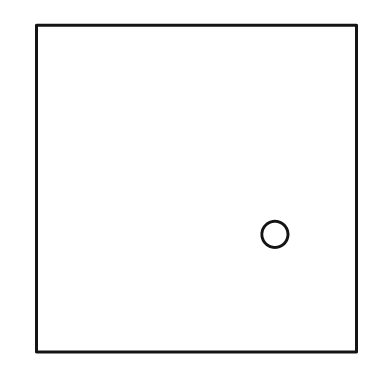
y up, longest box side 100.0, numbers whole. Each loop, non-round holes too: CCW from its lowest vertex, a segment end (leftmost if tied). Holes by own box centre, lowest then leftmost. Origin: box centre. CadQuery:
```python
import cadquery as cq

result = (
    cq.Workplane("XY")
    .moveTo(-49.0, -50.0)
    .lineTo(49.0, -50.0)
    .lineTo(49.0, 50.0)
    .lineTo(-49.0, 50.0)
    .close()
    .moveTo(24.0, -14.0)
    .circle(4.0)
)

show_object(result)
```